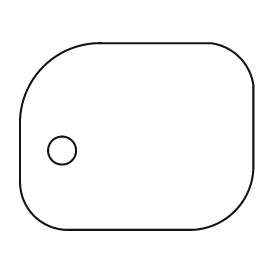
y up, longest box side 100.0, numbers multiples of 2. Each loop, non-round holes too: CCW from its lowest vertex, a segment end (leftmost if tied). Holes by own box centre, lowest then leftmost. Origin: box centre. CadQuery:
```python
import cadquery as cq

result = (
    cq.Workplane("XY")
    .moveTo(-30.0, -40.0)
    .lineTo(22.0, -40.0)
    .threePointArc((42.0, -32.0), (50.0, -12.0))
    .lineTo(50.0, 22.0)
    .threePointArc((44.0, 34.0), (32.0, 40.0))
    .lineTo(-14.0, 40.0)
    .threePointArc((-40.0, 30.0), (-50.0, 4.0))
    .lineTo(-50.0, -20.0)
    .threePointArc((-44.0, -34.0), (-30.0, -40.0))
    .close()
    .moveTo(-32.0, -6.0)
    .circle(6.0)
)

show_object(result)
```